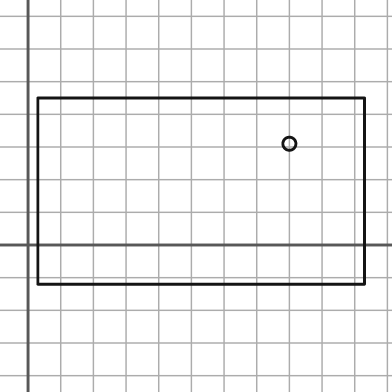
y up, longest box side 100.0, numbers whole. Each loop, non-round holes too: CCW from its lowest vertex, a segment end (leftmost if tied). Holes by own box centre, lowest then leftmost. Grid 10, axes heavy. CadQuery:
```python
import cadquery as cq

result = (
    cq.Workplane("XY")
    .moveTo(3.0, -12.0)
    .lineTo(103.0, -12.0)
    .lineTo(103.0, 45.0)
    .lineTo(3.0, 45.0)
    .close()
    .moveTo(80.0, 31.0)
    .circle(2.0)
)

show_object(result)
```